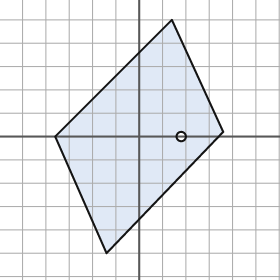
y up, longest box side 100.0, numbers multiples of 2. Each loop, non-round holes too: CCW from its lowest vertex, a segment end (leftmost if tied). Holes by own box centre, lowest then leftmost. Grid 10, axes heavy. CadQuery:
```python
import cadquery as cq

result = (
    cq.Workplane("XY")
    .moveTo(-14.0, -50.0)
    .lineTo(36.0, 2.0)
    .lineTo(14.0, 50.0)
    .lineTo(-36.0, 0.0)
    .close()
    .moveTo(18.0, 0.0)
    .circle(2.0)
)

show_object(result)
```